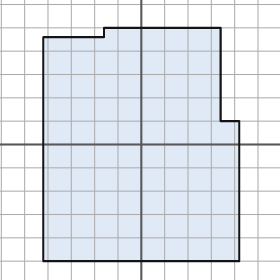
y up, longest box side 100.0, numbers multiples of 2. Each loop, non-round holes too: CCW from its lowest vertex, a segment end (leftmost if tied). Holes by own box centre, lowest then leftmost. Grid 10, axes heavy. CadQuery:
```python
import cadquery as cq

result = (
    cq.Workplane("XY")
    .moveTo(-42.0, -50.0)
    .lineTo(42.0, -50.0)
    .lineTo(42.0, 10.0)
    .lineTo(34.0, 10.0)
    .lineTo(34.0, 50.0)
    .lineTo(-16.0, 50.0)
    .lineTo(-16.0, 46.0)
    .lineTo(-42.0, 46.0)
    .close()
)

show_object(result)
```